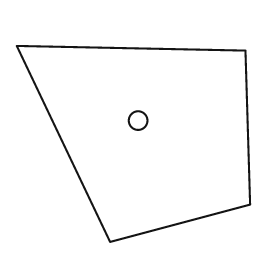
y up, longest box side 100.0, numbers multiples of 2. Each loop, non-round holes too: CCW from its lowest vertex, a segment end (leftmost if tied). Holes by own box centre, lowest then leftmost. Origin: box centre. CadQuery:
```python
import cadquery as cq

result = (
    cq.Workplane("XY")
    .moveTo(-10.0, -42.0)
    .lineTo(50.0, -26.0)
    .lineTo(48.0, 40.0)
    .lineTo(-50.0, 42.0)
    .close()
    .moveTo(2.0, 10.0)
    .circle(4.0)
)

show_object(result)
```